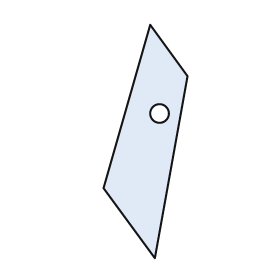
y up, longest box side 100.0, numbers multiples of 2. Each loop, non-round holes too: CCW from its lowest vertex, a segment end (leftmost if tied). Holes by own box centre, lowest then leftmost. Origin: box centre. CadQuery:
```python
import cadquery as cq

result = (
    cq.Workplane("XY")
    .moveTo(4.0, -50.0)
    .lineTo(18.0, 28.0)
    .lineTo(2.0, 50.0)
    .lineTo(-18.0, -20.0)
    .close()
    .moveTo(6.0, 12.0)
    .circle(4.0)
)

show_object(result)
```